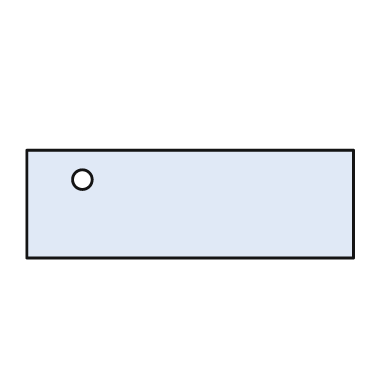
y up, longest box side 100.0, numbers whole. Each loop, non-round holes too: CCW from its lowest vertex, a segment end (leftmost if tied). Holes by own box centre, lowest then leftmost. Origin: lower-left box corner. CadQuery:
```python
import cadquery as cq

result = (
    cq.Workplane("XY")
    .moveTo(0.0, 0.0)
    .lineTo(100.0, 0.0)
    .lineTo(100.0, 33.0)
    .lineTo(0.0, 33.0)
    .close()
    .moveTo(17.0, 24.0)
    .circle(3.0)
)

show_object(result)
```